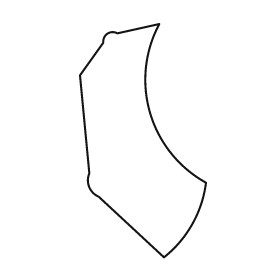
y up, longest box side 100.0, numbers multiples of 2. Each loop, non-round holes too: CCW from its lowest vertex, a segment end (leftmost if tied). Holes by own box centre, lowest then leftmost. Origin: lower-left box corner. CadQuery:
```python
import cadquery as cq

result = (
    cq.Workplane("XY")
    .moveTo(36.0, 0.0)
    .threePointArc((48.0, 14.0), (54.0, 32.0))
    .threePointArc((30.0, 62.0), (34.0, 100.0))
    .lineTo(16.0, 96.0)
    .threePointArc((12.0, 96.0), (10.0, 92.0))
    .lineTo(0.0, 78.0)
    .lineTo(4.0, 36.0)
    .threePointArc((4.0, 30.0), (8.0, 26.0))
    .close()
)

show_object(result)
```